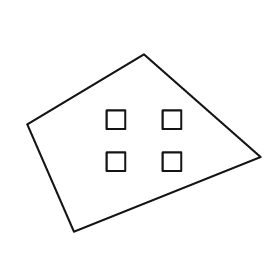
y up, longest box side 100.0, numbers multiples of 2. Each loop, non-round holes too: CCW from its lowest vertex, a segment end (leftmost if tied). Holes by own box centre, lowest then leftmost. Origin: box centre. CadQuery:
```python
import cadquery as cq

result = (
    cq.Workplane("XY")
    .moveTo(-30.0, -38.0)
    .lineTo(50.0, -6.0)
    .lineTo(0.0, 38.0)
    .lineTo(-50.0, 8.0)
    .close()
    .moveTo(-16.0, -12.0)
    .lineTo(-8.0, -12.0)
    .lineTo(-8.0, -4.0)
    .lineTo(-16.0, -4.0)
    .close()
    .moveTo(8.0, -12.0)
    .lineTo(16.0, -12.0)
    .lineTo(16.0, -4.0)
    .lineTo(8.0, -4.0)
    .close()
    .moveTo(-16.0, 6.0)
    .lineTo(-8.0, 6.0)
    .lineTo(-8.0, 14.0)
    .lineTo(-16.0, 14.0)
    .close()
    .moveTo(8.0, 6.0)
    .lineTo(16.0, 6.0)
    .lineTo(16.0, 14.0)
    .lineTo(8.0, 14.0)
    .close()
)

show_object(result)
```